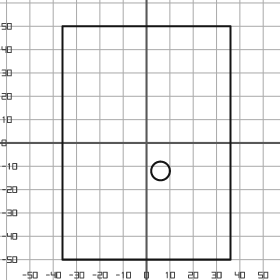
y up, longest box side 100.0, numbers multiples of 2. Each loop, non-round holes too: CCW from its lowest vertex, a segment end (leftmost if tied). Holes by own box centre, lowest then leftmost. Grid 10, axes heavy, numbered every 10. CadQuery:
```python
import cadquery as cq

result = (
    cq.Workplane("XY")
    .moveTo(-36.0, -50.0)
    .lineTo(36.0, -50.0)
    .lineTo(36.0, 50.0)
    .lineTo(-36.0, 50.0)
    .close()
    .moveTo(6.0, -12.0)
    .circle(4.0)
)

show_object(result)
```